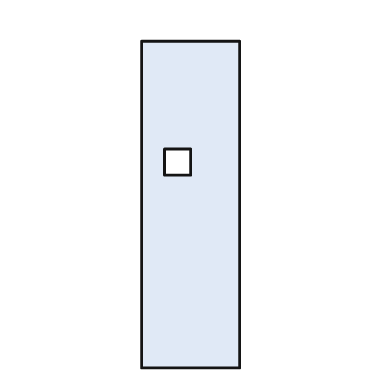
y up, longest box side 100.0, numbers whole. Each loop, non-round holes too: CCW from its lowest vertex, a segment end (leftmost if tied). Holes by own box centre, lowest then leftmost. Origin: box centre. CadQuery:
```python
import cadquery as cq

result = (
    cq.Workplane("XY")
    .moveTo(-15.0, -50.0)
    .lineTo(15.0, -50.0)
    .lineTo(15.0, 50.0)
    .lineTo(-15.0, 50.0)
    .close()
    .moveTo(-8.0, 9.0)
    .lineTo(0.0, 9.0)
    .lineTo(0.0, 17.0)
    .lineTo(-8.0, 17.0)
    .close()
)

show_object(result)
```